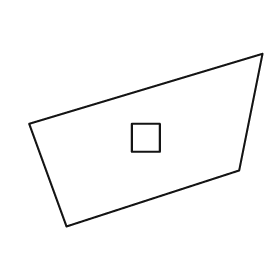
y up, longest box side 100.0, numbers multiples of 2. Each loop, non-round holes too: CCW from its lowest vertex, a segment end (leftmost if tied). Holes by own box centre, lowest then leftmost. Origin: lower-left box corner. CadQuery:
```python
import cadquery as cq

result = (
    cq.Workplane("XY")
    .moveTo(16.0, 0.0)
    .lineTo(90.0, 24.0)
    .lineTo(100.0, 74.0)
    .lineTo(0.0, 44.0)
    .close()
    .moveTo(44.0, 32.0)
    .lineTo(56.0, 32.0)
    .lineTo(56.0, 44.0)
    .lineTo(44.0, 44.0)
    .close()
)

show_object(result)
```